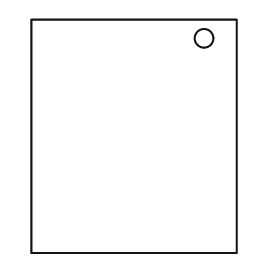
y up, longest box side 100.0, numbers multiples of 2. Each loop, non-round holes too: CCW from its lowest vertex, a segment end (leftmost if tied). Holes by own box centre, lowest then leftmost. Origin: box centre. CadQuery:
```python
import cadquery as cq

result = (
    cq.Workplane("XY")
    .moveTo(-44.0, -50.0)
    .lineTo(44.0, -50.0)
    .lineTo(44.0, 50.0)
    .lineTo(-44.0, 50.0)
    .close()
    .moveTo(30.0, 42.0)
    .circle(4.0)
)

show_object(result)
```